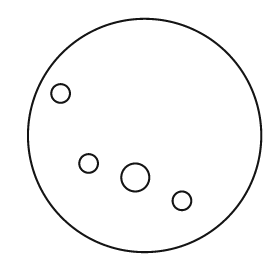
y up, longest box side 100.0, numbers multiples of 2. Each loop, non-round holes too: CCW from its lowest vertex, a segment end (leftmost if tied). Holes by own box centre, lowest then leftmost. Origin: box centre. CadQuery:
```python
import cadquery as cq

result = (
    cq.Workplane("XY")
    .moveTo(0.0, 0.0)
    .circle(50.0)
    .moveTo(16.0, -28.0)
    .circle(4.0)
    .moveTo(-4.0, -18.0)
    .circle(6.0)
    .moveTo(-24.0, -12.0)
    .circle(4.0)
    .moveTo(-36.0, 18.0)
    .circle(4.0)
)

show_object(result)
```